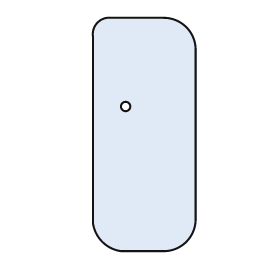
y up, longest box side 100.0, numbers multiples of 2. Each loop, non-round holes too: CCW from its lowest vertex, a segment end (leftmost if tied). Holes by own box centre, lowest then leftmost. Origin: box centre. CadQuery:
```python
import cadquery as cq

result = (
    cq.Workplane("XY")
    .moveTo(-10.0, -50.0)
    .lineTo(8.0, -50.0)
    .threePointArc((18.0, -46.0), (22.0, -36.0))
    .lineTo(22.0, 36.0)
    .threePointArc((18.0, 46.0), (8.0, 50.0))
    .lineTo(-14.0, 50.0)
    .threePointArc((-20.0, 48.0), (-22.0, 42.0))
    .lineTo(-22.0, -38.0)
    .threePointArc((-18.0, -46.0), (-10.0, -50.0))
    .close()
    .moveTo(-8.0, 12.0)
    .circle(2.0)
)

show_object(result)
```